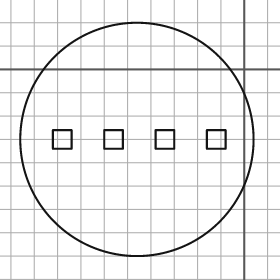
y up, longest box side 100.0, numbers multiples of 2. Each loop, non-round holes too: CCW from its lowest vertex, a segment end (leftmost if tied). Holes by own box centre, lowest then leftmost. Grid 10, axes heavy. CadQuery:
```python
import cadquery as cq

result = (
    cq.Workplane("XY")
    .moveTo(-46.0, -30.0)
    .circle(50.0)
    .moveTo(-82.0, -34.0)
    .lineTo(-74.0, -34.0)
    .lineTo(-74.0, -26.0)
    .lineTo(-82.0, -26.0)
    .close()
    .moveTo(-60.0, -34.0)
    .lineTo(-52.0, -34.0)
    .lineTo(-52.0, -26.0)
    .lineTo(-60.0, -26.0)
    .close()
    .moveTo(-38.0, -34.0)
    .lineTo(-30.0, -34.0)
    .lineTo(-30.0, -26.0)
    .lineTo(-38.0, -26.0)
    .close()
    .moveTo(-16.0, -34.0)
    .lineTo(-8.0, -34.0)
    .lineTo(-8.0, -26.0)
    .lineTo(-16.0, -26.0)
    .close()
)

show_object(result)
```